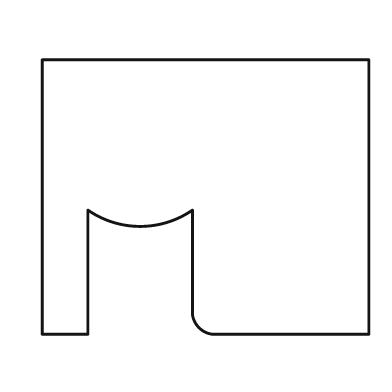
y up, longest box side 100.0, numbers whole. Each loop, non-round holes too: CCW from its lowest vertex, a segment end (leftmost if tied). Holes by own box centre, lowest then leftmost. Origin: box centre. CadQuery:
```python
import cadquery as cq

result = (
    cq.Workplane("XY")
    .moveTo(-50.0, -42.0)
    .lineTo(-36.0, -42.0)
    .lineTo(-36.0, -4.0)
    .threePointArc((-20.0, -9.0), (-4.0, -4.0))
    .lineTo(-4.0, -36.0)
    .threePointArc((-2.0, -40.0), (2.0, -42.0))
    .lineTo(50.0, -42.0)
    .lineTo(50.0, 42.0)
    .lineTo(-50.0, 42.0)
    .close()
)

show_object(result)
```